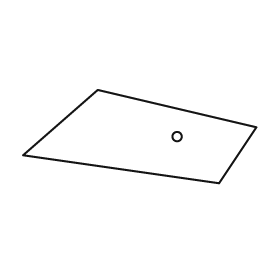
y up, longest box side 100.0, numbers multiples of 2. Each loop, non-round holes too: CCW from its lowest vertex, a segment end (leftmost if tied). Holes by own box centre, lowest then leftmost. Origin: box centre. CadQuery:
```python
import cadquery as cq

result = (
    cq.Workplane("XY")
    .moveTo(34.0, -20.0)
    .lineTo(50.0, 4.0)
    .lineTo(-18.0, 20.0)
    .lineTo(-50.0, -8.0)
    .close()
    .moveTo(16.0, 0.0)
    .circle(2.0)
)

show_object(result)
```